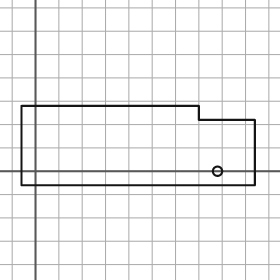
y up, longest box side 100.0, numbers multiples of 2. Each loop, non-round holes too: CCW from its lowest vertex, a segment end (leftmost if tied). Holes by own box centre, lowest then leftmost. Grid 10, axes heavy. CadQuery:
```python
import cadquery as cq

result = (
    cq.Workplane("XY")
    .moveTo(-6.0, -6.0)
    .lineTo(94.0, -6.0)
    .lineTo(94.0, 22.0)
    .lineTo(70.0, 22.0)
    .lineTo(70.0, 28.0)
    .lineTo(-6.0, 28.0)
    .close()
    .moveTo(78.0, 0.0)
    .circle(2.0)
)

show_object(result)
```